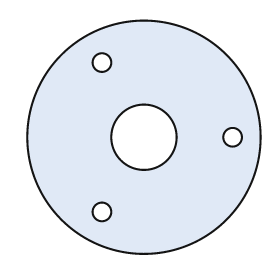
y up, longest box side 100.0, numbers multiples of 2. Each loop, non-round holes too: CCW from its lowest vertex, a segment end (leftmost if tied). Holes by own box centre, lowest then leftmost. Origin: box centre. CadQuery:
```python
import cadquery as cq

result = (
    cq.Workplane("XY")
    .moveTo(0.0, 0.0)
    .circle(50.0)
    .moveTo(-18.0, -32.0)
    .circle(4.0)
    .moveTo(0.0, 0.0)
    .circle(14.0)
    .moveTo(38.0, 0.0)
    .circle(4.0)
    .moveTo(-18.0, 32.0)
    .circle(4.0)
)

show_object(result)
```